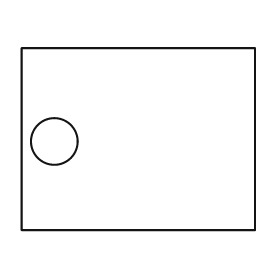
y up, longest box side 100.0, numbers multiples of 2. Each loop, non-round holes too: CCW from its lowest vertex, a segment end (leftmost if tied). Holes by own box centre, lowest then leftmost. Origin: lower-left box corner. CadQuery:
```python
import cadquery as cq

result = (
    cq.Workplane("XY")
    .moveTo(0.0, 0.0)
    .lineTo(100.0, 0.0)
    .lineTo(100.0, 78.0)
    .lineTo(0.0, 78.0)
    .close()
    .moveTo(14.0, 38.0)
    .circle(10.0)
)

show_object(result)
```